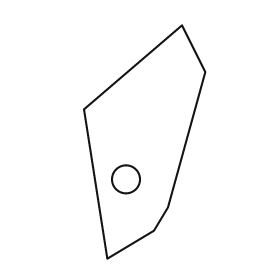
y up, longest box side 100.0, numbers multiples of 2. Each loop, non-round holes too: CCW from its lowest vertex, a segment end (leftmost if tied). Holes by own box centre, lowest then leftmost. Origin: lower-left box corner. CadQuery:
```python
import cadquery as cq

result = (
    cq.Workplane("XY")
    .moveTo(10.0, 0.0)
    .lineTo(30.0, 12.0)
    .lineTo(36.0, 22.0)
    .lineTo(52.0, 80.0)
    .lineTo(42.0, 100.0)
    .lineTo(0.0, 64.0)
    .close()
    .moveTo(18.0, 34.0)
    .circle(6.0)
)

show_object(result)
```